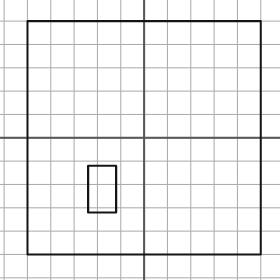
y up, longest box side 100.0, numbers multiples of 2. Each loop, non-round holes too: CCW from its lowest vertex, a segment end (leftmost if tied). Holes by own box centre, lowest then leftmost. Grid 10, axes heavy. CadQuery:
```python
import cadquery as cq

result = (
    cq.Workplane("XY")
    .moveTo(-50.0, -50.0)
    .lineTo(50.0, -50.0)
    .lineTo(50.0, 50.0)
    .lineTo(-50.0, 50.0)
    .close()
    .moveTo(-24.0, -32.0)
    .lineTo(-12.0, -32.0)
    .lineTo(-12.0, -12.0)
    .lineTo(-24.0, -12.0)
    .close()
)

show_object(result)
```